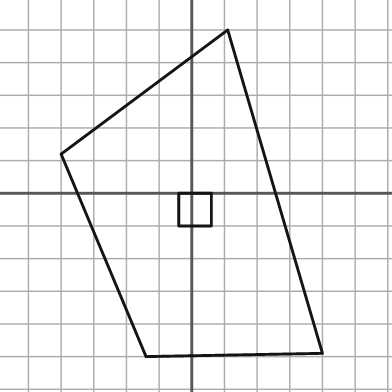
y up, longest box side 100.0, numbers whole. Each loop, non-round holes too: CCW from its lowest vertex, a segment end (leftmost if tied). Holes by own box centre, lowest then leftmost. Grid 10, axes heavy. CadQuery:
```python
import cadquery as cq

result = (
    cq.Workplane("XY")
    .moveTo(-14.0, -50.0)
    .lineTo(40.0, -49.0)
    .lineTo(11.0, 50.0)
    .lineTo(-40.0, 12.0)
    .close()
    .moveTo(-4.0, -10.0)
    .lineTo(6.0, -10.0)
    .lineTo(6.0, 0.0)
    .lineTo(-4.0, 0.0)
    .close()
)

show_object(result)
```